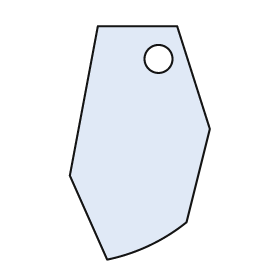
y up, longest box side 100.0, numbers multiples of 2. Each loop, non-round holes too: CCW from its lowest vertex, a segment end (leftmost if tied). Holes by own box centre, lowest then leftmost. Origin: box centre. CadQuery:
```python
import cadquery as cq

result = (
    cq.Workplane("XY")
    .moveTo(-14.0, -50.0)
    .threePointArc((4.0, -44.0), (20.0, -34.0))
    .lineTo(30.0, 6.0)
    .lineTo(16.0, 50.0)
    .lineTo(-18.0, 50.0)
    .lineTo(-30.0, -14.0)
    .close()
    .moveTo(8.0, 36.0)
    .circle(6.0)
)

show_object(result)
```